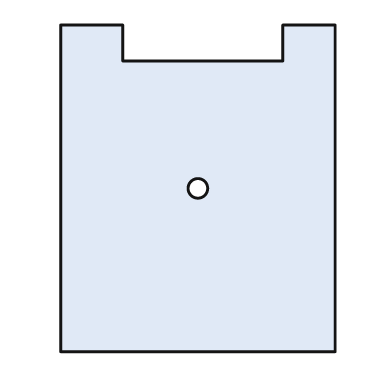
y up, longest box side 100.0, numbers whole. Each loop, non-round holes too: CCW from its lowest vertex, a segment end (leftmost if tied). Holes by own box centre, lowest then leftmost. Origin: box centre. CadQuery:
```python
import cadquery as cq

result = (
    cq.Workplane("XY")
    .moveTo(-42.0, -50.0)
    .lineTo(42.0, -50.0)
    .lineTo(42.0, 50.0)
    .lineTo(26.0, 50.0)
    .lineTo(26.0, 39.0)
    .lineTo(-23.0, 39.0)
    .lineTo(-23.0, 50.0)
    .lineTo(-42.0, 50.0)
    .close()
    .moveTo(0.0, 0.0)
    .circle(3.0)
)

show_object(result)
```